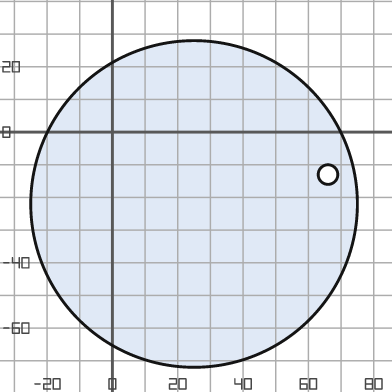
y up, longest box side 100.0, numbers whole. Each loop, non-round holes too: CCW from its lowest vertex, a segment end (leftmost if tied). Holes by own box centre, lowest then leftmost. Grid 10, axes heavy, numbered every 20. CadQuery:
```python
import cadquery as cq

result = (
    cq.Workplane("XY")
    .moveTo(25.0, -22.0)
    .circle(50.0)
    .moveTo(66.0, -13.0)
    .circle(3.0)
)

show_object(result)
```